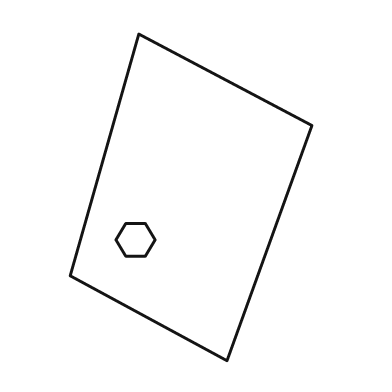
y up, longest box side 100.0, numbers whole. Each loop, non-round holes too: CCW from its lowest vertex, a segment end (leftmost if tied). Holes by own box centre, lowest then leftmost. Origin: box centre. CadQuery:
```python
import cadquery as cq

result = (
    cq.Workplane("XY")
    .moveTo(11.0, -50.0)
    .lineTo(37.0, 22.0)
    .lineTo(-16.0, 50.0)
    .lineTo(-37.0, -24.0)
    .close()
    .moveTo(-20.0, -18.0)
    .lineTo(-14.0, -18.0)
    .lineTo(-11.0, -13.0)
    .lineTo(-14.0, -8.0)
    .lineTo(-20.0, -8.0)
    .lineTo(-23.0, -13.0)
    .close()
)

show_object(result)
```